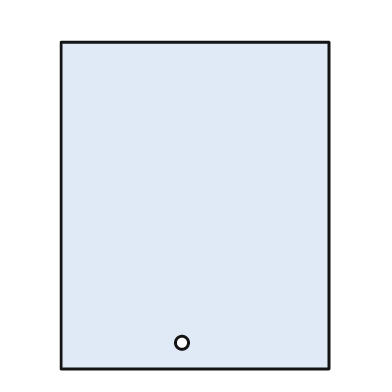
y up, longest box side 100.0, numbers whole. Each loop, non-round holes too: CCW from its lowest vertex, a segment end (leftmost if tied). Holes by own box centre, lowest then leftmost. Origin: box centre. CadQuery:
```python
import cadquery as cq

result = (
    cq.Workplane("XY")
    .moveTo(-41.0, -50.0)
    .lineTo(41.0, -50.0)
    .lineTo(41.0, 50.0)
    .lineTo(-41.0, 50.0)
    .close()
    .moveTo(-4.0, -42.0)
    .circle(2.0)
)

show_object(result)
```